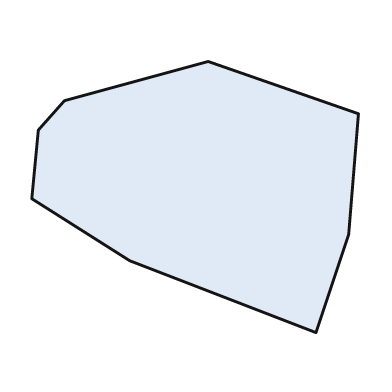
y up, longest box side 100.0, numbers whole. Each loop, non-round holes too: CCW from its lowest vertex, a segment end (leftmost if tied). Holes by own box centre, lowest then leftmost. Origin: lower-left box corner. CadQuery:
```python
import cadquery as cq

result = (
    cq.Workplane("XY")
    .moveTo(87.0, 0.0)
    .lineTo(97.0, 30.0)
    .lineTo(100.0, 67.0)
    .lineTo(54.0, 83.0)
    .lineTo(10.0, 71.0)
    .lineTo(2.0, 62.0)
    .lineTo(0.0, 41.0)
    .lineTo(30.0, 22.0)
    .close()
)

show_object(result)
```